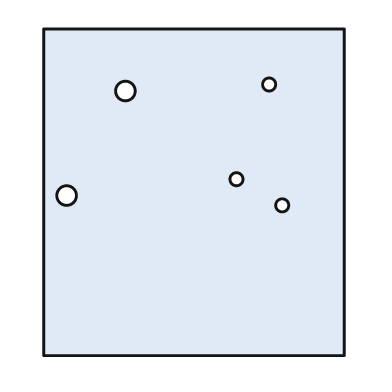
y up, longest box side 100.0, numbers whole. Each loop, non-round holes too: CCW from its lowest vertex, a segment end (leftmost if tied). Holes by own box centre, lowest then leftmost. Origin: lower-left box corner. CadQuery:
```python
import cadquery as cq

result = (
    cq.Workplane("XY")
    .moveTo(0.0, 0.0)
    .lineTo(92.0, 0.0)
    .lineTo(92.0, 100.0)
    .lineTo(0.0, 100.0)
    .close()
    .moveTo(73.0, 46.0)
    .circle(2.0)
    .moveTo(7.0, 49.0)
    .circle(3.0)
    .moveTo(59.0, 54.0)
    .circle(2.0)
    .moveTo(25.0, 81.0)
    .circle(3.0)
    .moveTo(69.0, 83.0)
    .circle(2.0)
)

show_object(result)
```